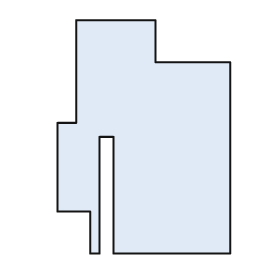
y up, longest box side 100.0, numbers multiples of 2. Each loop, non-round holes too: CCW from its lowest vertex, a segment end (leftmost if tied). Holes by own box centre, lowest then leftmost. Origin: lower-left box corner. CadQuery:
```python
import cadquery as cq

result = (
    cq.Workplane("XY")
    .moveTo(14.0, 0.0)
    .lineTo(18.0, 0.0)
    .lineTo(18.0, 50.0)
    .lineTo(24.0, 50.0)
    .lineTo(24.0, 0.0)
    .lineTo(74.0, 0.0)
    .lineTo(74.0, 82.0)
    .lineTo(42.0, 82.0)
    .lineTo(42.0, 100.0)
    .lineTo(8.0, 100.0)
    .lineTo(8.0, 56.0)
    .lineTo(0.0, 56.0)
    .lineTo(0.0, 18.0)
    .lineTo(14.0, 18.0)
    .close()
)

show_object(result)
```